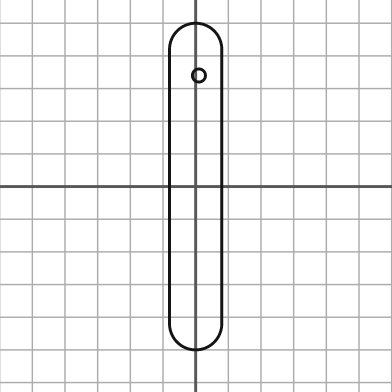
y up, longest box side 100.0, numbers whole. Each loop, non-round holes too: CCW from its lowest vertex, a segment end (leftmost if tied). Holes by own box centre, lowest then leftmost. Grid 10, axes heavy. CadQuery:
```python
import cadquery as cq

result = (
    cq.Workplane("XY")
    .moveTo(-8.0, -42.0)
    .threePointArc((0.0, -50.0), (8.0, -42.0))
    .lineTo(8.0, 42.0)
    .threePointArc((0.0, 50.0), (-8.0, 42.0))
    .close()
    .moveTo(1.0, 34.0)
    .circle(2.0)
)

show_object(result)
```